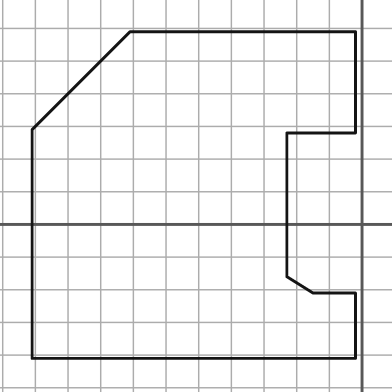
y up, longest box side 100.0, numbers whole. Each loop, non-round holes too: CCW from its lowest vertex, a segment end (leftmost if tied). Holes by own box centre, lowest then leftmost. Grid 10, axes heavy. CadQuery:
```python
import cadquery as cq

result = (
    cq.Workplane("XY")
    .moveTo(-101.0, -41.0)
    .lineTo(-2.0, -41.0)
    .lineTo(-2.0, -21.0)
    .lineTo(-15.0, -21.0)
    .lineTo(-23.0, -16.0)
    .lineTo(-23.0, 28.0)
    .lineTo(-2.0, 28.0)
    .lineTo(-2.0, 59.0)
    .lineTo(-71.0, 59.0)
    .lineTo(-101.0, 29.0)
    .close()
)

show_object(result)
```